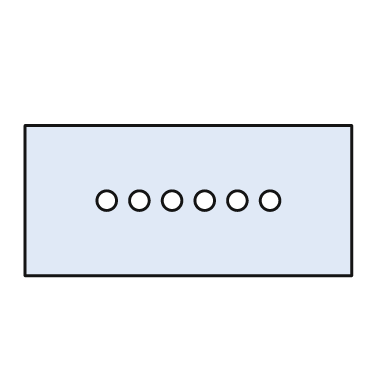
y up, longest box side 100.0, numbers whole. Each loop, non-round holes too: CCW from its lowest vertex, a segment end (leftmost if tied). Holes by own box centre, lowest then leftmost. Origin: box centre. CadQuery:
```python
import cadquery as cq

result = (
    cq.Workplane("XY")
    .moveTo(-50.0, -23.0)
    .lineTo(50.0, -23.0)
    .lineTo(50.0, 23.0)
    .lineTo(-50.0, 23.0)
    .close()
    .moveTo(-25.0, 0.0)
    .circle(3.0)
    .moveTo(-15.0, 0.0)
    .circle(3.0)
    .moveTo(-5.0, 0.0)
    .circle(3.0)
    .moveTo(5.0, 0.0)
    .circle(3.0)
    .moveTo(15.0, 0.0)
    .circle(3.0)
    .moveTo(25.0, 0.0)
    .circle(3.0)
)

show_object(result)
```